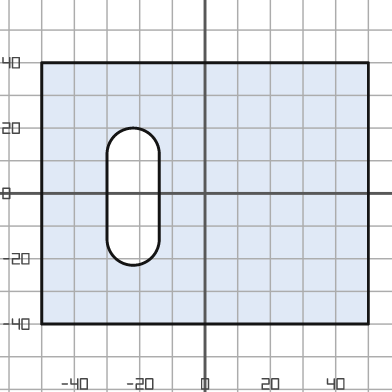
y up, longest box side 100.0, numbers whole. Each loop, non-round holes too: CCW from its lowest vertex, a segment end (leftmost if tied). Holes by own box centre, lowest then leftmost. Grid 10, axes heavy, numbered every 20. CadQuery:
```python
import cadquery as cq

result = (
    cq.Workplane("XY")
    .moveTo(-50.0, -40.0)
    .lineTo(50.0, -40.0)
    .lineTo(50.0, 40.0)
    .lineTo(-50.0, 40.0)
    .close()
    .moveTo(-30.0, -14.0)
    .threePointArc((-22.0, -22.0), (-14.0, -14.0))
    .lineTo(-14.0, 12.0)
    .threePointArc((-22.0, 20.0), (-30.0, 12.0))
    .close()
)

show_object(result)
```